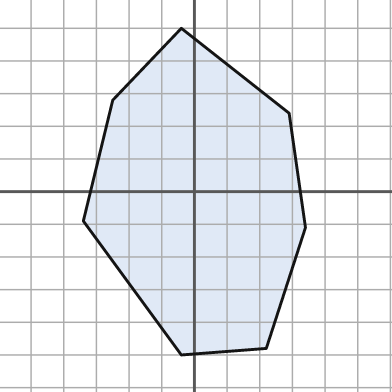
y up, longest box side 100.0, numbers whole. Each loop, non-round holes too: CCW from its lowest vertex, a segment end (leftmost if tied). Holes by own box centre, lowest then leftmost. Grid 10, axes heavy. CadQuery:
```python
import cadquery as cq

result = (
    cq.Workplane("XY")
    .moveTo(-4.0, -50.0)
    .lineTo(22.0, -48.0)
    .lineTo(34.0, -11.0)
    .lineTo(29.0, 24.0)
    .lineTo(-4.0, 50.0)
    .lineTo(-25.0, 28.0)
    .lineTo(-34.0, -9.0)
    .close()
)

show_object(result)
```